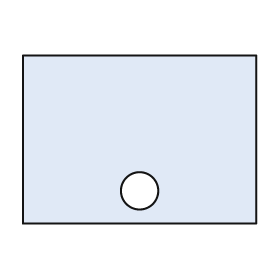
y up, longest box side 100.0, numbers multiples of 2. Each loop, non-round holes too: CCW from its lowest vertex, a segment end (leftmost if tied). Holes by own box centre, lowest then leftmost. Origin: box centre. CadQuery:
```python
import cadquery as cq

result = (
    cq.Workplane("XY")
    .moveTo(-50.0, -36.0)
    .lineTo(50.0, -36.0)
    .lineTo(50.0, 36.0)
    .lineTo(-50.0, 36.0)
    .close()
    .moveTo(0.0, -22.0)
    .circle(8.0)
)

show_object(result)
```